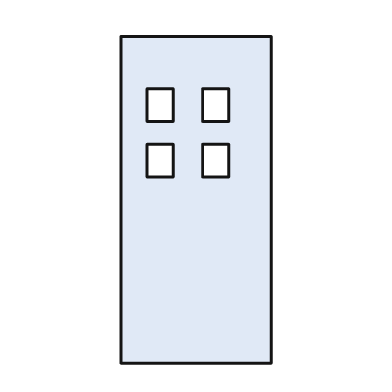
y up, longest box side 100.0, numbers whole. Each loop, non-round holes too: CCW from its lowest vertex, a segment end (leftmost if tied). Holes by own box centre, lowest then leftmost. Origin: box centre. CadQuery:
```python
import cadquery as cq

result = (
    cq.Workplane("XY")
    .moveTo(-23.0, -50.0)
    .lineTo(23.0, -50.0)
    .lineTo(23.0, 50.0)
    .lineTo(-23.0, 50.0)
    .close()
    .moveTo(-15.0, 7.0)
    .lineTo(-7.0, 7.0)
    .lineTo(-7.0, 17.0)
    .lineTo(-15.0, 17.0)
    .close()
    .moveTo(2.0, 7.0)
    .lineTo(10.0, 7.0)
    .lineTo(10.0, 17.0)
    .lineTo(2.0, 17.0)
    .close()
    .moveTo(-15.0, 24.0)
    .lineTo(-7.0, 24.0)
    .lineTo(-7.0, 34.0)
    .lineTo(-15.0, 34.0)
    .close()
    .moveTo(2.0, 24.0)
    .lineTo(10.0, 24.0)
    .lineTo(10.0, 34.0)
    .lineTo(2.0, 34.0)
    .close()
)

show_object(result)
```